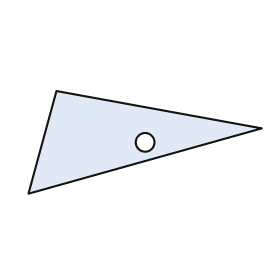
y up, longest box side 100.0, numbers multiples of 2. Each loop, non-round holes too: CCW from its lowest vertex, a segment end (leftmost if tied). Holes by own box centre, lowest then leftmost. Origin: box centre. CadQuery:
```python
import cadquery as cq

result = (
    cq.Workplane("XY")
    .moveTo(-50.0, -22.0)
    .lineTo(50.0, 6.0)
    .lineTo(-38.0, 22.0)
    .close()
    .moveTo(0.0, 0.0)
    .circle(4.0)
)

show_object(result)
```